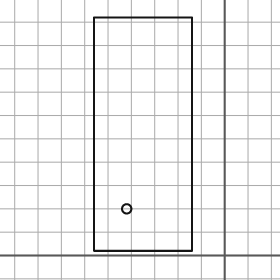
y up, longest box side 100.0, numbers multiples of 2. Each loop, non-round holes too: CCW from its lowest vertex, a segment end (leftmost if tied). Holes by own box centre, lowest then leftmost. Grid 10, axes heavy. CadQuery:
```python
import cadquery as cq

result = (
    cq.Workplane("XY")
    .moveTo(-56.0, 2.0)
    .lineTo(-14.0, 2.0)
    .lineTo(-14.0, 102.0)
    .lineTo(-56.0, 102.0)
    .close()
    .moveTo(-42.0, 20.0)
    .circle(2.0)
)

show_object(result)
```